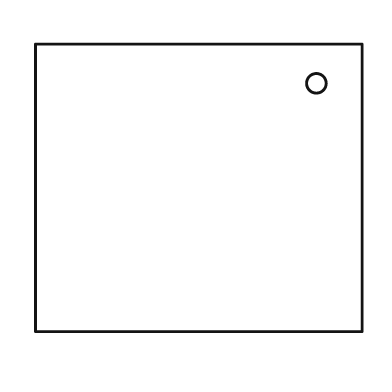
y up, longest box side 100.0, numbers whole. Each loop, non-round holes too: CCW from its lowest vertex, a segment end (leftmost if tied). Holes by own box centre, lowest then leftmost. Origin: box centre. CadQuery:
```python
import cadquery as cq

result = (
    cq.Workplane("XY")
    .moveTo(-50.0, -44.0)
    .lineTo(50.0, -44.0)
    .lineTo(50.0, 44.0)
    .lineTo(-50.0, 44.0)
    .close()
    .moveTo(36.0, 32.0)
    .circle(3.0)
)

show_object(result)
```